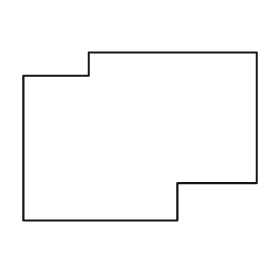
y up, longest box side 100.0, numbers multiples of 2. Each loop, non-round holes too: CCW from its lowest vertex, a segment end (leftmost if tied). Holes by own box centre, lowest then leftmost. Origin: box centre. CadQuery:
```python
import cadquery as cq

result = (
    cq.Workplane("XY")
    .moveTo(-50.0, -36.0)
    .lineTo(16.0, -36.0)
    .lineTo(16.0, -20.0)
    .lineTo(50.0, -20.0)
    .lineTo(50.0, 36.0)
    .lineTo(-22.0, 36.0)
    .lineTo(-22.0, 26.0)
    .lineTo(-50.0, 26.0)
    .close()
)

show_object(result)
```